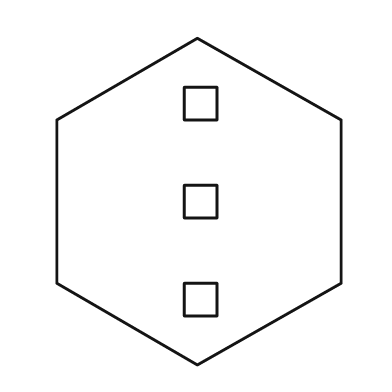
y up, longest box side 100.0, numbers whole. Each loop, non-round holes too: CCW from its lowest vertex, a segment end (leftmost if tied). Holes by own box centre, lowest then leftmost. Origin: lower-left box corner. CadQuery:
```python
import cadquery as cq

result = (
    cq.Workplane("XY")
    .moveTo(43.0, 0.0)
    .lineTo(87.0, 25.0)
    .lineTo(87.0, 75.0)
    .lineTo(43.0, 100.0)
    .lineTo(0.0, 75.0)
    .lineTo(0.0, 25.0)
    .close()
    .moveTo(39.0, 15.0)
    .lineTo(49.0, 15.0)
    .lineTo(49.0, 25.0)
    .lineTo(39.0, 25.0)
    .close()
    .moveTo(39.0, 45.0)
    .lineTo(49.0, 45.0)
    .lineTo(49.0, 55.0)
    .lineTo(39.0, 55.0)
    .close()
    .moveTo(39.0, 75.0)
    .lineTo(49.0, 75.0)
    .lineTo(49.0, 85.0)
    .lineTo(39.0, 85.0)
    .close()
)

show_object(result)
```